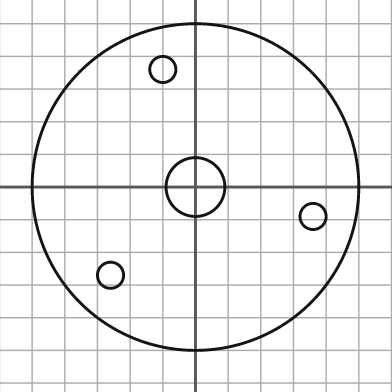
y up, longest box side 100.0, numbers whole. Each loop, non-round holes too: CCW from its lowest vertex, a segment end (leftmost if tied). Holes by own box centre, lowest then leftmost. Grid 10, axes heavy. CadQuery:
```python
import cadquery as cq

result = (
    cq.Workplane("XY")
    .moveTo(0.0, 0.0)
    .circle(50.0)
    .moveTo(-26.0, -27.0)
    .circle(4.0)
    .moveTo(36.0, -9.0)
    .circle(4.0)
    .moveTo(0.0, 0.0)
    .circle(9.0)
    .moveTo(-10.0, 36.0)
    .circle(4.0)
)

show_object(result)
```